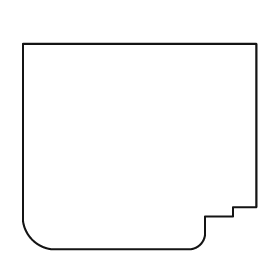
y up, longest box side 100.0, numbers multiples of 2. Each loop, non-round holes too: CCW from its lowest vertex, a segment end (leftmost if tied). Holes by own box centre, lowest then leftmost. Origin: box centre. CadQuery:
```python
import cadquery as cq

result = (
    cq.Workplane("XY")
    .moveTo(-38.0, -44.0)
    .lineTo(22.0, -44.0)
    .threePointArc((26.0, -42.0), (28.0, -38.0))
    .lineTo(28.0, -30.0)
    .lineTo(40.0, -30.0)
    .lineTo(40.0, -26.0)
    .lineTo(50.0, -26.0)
    .lineTo(50.0, 44.0)
    .lineTo(-50.0, 44.0)
    .lineTo(-50.0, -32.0)
    .threePointArc((-46.0, -40.0), (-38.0, -44.0))
    .close()
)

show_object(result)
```